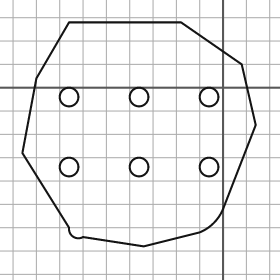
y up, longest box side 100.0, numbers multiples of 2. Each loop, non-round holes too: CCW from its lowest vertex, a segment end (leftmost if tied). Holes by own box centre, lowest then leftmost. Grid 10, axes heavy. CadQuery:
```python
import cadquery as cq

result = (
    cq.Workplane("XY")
    .moveTo(-34.0, -68.0)
    .lineTo(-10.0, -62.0)
    .threePointArc((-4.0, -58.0), (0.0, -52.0))
    .lineTo(14.0, -16.0)
    .lineTo(8.0, 10.0)
    .lineTo(-18.0, 28.0)
    .lineTo(-66.0, 28.0)
    .lineTo(-80.0, 4.0)
    .lineTo(-86.0, -28.0)
    .lineTo(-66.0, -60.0)
    .threePointArc((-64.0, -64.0), (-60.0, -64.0))
    .close()
    .moveTo(-66.0, -34.0)
    .circle(4.0)
    .moveTo(-36.0, -34.0)
    .circle(4.0)
    .moveTo(-6.0, -34.0)
    .circle(4.0)
    .moveTo(-66.0, -4.0)
    .circle(4.0)
    .moveTo(-36.0, -4.0)
    .circle(4.0)
    .moveTo(-6.0, -4.0)
    .circle(4.0)
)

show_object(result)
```